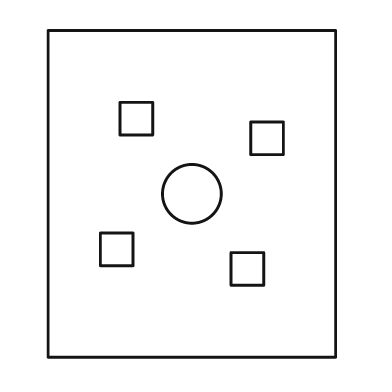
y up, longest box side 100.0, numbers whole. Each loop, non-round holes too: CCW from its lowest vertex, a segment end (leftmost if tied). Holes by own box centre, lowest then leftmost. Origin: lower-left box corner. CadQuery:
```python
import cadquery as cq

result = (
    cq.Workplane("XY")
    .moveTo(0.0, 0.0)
    .lineTo(88.0, 0.0)
    .lineTo(88.0, 100.0)
    .lineTo(0.0, 100.0)
    .close()
    .moveTo(56.0, 22.0)
    .lineTo(66.0, 22.0)
    .lineTo(66.0, 32.0)
    .lineTo(56.0, 32.0)
    .close()
    .moveTo(16.0, 28.0)
    .lineTo(26.0, 28.0)
    .lineTo(26.0, 38.0)
    .lineTo(16.0, 38.0)
    .close()
    .moveTo(44.0, 50.0)
    .circle(9.0)
    .moveTo(62.0, 62.0)
    .lineTo(72.0, 62.0)
    .lineTo(72.0, 72.0)
    .lineTo(62.0, 72.0)
    .close()
    .moveTo(22.0, 68.0)
    .lineTo(32.0, 68.0)
    .lineTo(32.0, 78.0)
    .lineTo(22.0, 78.0)
    .close()
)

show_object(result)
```